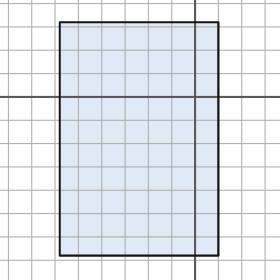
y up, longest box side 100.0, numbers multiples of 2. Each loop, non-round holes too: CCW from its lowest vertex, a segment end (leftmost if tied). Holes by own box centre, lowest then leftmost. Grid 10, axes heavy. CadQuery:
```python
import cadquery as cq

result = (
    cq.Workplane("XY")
    .moveTo(-58.0, -68.0)
    .lineTo(10.0, -68.0)
    .lineTo(10.0, 32.0)
    .lineTo(-58.0, 32.0)
    .close()
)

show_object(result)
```